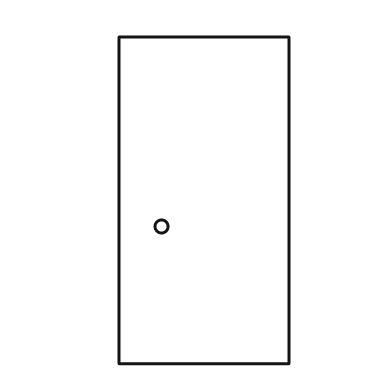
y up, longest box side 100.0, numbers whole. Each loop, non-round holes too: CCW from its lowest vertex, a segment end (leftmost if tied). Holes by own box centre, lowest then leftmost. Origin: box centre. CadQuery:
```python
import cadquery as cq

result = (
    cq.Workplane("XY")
    .moveTo(-26.0, -50.0)
    .lineTo(26.0, -50.0)
    .lineTo(26.0, 50.0)
    .lineTo(-26.0, 50.0)
    .close()
    .moveTo(-13.0, -8.0)
    .circle(2.0)
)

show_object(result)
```